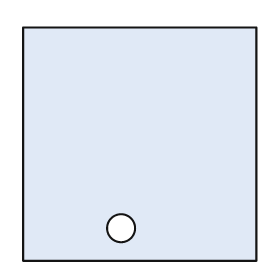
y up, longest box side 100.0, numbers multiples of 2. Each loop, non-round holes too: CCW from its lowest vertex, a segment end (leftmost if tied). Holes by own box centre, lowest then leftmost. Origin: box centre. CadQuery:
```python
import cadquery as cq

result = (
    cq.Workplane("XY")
    .moveTo(-50.0, -50.0)
    .lineTo(50.0, -50.0)
    .lineTo(50.0, 50.0)
    .lineTo(-50.0, 50.0)
    .close()
    .moveTo(-8.0, -36.0)
    .circle(6.0)
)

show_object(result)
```